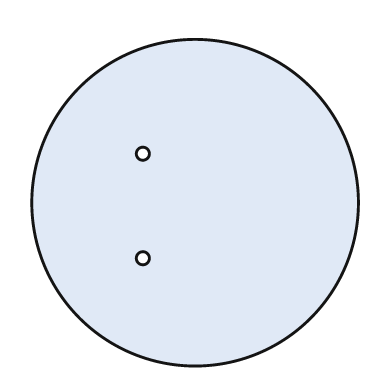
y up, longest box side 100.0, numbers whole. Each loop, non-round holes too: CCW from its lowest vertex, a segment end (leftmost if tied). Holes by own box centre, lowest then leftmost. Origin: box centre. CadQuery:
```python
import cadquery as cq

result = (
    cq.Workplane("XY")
    .moveTo(0.0, 0.0)
    .circle(50.0)
    .moveTo(-16.0, -17.0)
    .circle(2.0)
    .moveTo(-16.0, 15.0)
    .circle(2.0)
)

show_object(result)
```